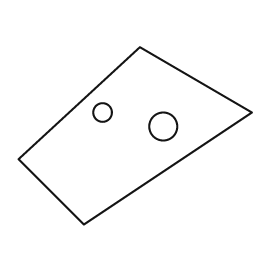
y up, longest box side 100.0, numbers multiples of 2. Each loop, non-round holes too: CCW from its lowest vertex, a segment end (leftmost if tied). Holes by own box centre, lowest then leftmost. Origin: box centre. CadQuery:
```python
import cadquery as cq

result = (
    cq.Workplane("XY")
    .moveTo(-22.0, -38.0)
    .lineTo(50.0, 10.0)
    .lineTo(2.0, 38.0)
    .lineTo(-50.0, -10.0)
    .close()
    .moveTo(12.0, 4.0)
    .circle(6.0)
    .moveTo(-14.0, 10.0)
    .circle(4.0)
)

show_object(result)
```